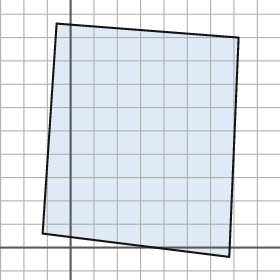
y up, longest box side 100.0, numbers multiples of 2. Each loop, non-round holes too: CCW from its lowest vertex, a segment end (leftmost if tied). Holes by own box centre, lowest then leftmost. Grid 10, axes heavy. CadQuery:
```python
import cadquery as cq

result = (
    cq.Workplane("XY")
    .moveTo(68.0, -4.0)
    .lineTo(72.0, 90.0)
    .lineTo(-6.0, 96.0)
    .lineTo(-12.0, 6.0)
    .close()
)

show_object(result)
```